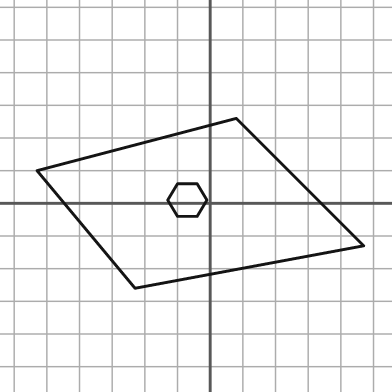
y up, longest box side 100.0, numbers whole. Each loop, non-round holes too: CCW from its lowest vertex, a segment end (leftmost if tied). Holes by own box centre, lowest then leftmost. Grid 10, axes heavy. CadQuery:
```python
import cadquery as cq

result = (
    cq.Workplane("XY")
    .moveTo(-23.0, -26.0)
    .lineTo(47.0, -13.0)
    .lineTo(8.0, 26.0)
    .lineTo(-53.0, 10.0)
    .close()
    .moveTo(-10.0, -4.0)
    .lineTo(-4.0, -4.0)
    .lineTo(-1.0, 1.0)
    .lineTo(-4.0, 6.0)
    .lineTo(-10.0, 6.0)
    .lineTo(-13.0, 1.0)
    .close()
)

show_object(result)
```